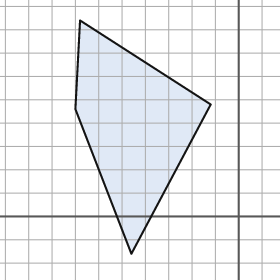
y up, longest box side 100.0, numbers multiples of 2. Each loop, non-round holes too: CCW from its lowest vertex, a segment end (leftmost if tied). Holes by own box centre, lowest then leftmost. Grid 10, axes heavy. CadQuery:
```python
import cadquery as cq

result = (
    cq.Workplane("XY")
    .moveTo(-46.0, -16.0)
    .lineTo(-12.0, 48.0)
    .lineTo(-68.0, 84.0)
    .lineTo(-70.0, 46.0)
    .close()
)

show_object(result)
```